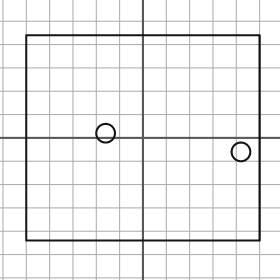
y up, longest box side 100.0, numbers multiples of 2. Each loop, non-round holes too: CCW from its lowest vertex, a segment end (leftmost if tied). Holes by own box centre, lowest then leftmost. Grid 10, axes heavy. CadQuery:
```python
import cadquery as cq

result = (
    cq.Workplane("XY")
    .moveTo(-50.0, -44.0)
    .lineTo(50.0, -44.0)
    .lineTo(50.0, 44.0)
    .lineTo(-50.0, 44.0)
    .close()
    .moveTo(42.0, -6.0)
    .circle(4.0)
    .moveTo(-16.0, 2.0)
    .circle(4.0)
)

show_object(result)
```